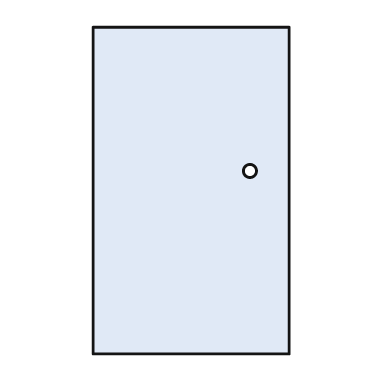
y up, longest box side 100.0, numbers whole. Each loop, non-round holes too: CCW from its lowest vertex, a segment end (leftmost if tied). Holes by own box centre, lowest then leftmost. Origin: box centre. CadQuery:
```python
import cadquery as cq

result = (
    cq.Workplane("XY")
    .moveTo(-30.0, -50.0)
    .lineTo(30.0, -50.0)
    .lineTo(30.0, 50.0)
    .lineTo(-30.0, 50.0)
    .close()
    .moveTo(18.0, 6.0)
    .circle(2.0)
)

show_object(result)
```